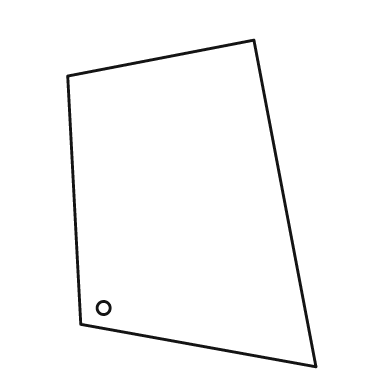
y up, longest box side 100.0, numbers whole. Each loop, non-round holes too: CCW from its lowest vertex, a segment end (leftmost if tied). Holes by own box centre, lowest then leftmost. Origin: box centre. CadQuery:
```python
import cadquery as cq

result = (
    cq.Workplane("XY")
    .moveTo(38.0, -50.0)
    .lineTo(19.0, 50.0)
    .lineTo(-38.0, 39.0)
    .lineTo(-34.0, -37.0)
    .close()
    .moveTo(-27.0, -32.0)
    .circle(2.0)
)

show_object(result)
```